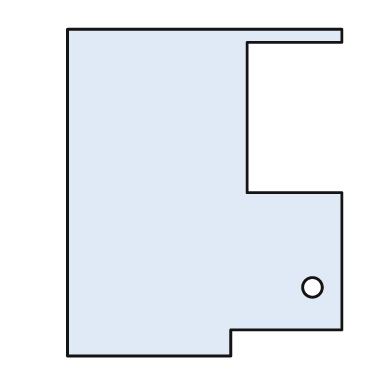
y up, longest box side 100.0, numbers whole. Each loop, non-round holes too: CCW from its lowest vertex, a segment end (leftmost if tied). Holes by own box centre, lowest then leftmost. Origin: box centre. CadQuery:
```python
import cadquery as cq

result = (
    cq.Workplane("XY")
    .moveTo(-42.0, -50.0)
    .lineTo(8.0, -50.0)
    .lineTo(8.0, -42.0)
    .lineTo(42.0, -42.0)
    .lineTo(42.0, 0.0)
    .lineTo(13.0, 0.0)
    .lineTo(13.0, 46.0)
    .lineTo(42.0, 46.0)
    .lineTo(42.0, 50.0)
    .lineTo(-42.0, 50.0)
    .close()
    .moveTo(33.0, -29.0)
    .circle(3.0)
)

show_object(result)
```